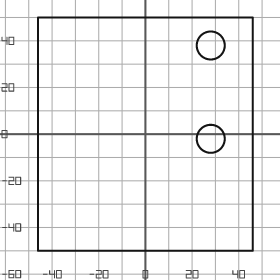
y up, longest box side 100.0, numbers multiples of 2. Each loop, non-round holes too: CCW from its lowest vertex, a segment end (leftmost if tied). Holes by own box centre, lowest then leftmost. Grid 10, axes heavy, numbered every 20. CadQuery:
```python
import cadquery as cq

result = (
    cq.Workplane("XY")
    .moveTo(-46.0, -50.0)
    .lineTo(46.0, -50.0)
    .lineTo(46.0, 50.0)
    .lineTo(-46.0, 50.0)
    .close()
    .moveTo(28.0, -2.0)
    .circle(6.0)
    .moveTo(28.0, 38.0)
    .circle(6.0)
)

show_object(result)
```